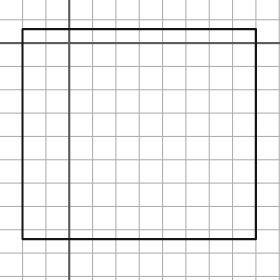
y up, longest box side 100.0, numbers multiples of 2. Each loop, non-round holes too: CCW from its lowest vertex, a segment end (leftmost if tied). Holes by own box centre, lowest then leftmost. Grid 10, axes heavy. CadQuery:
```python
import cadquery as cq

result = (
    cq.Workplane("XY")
    .moveTo(-20.0, -84.0)
    .lineTo(80.0, -84.0)
    .lineTo(80.0, 6.0)
    .lineTo(-20.0, 6.0)
    .close()
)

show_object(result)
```